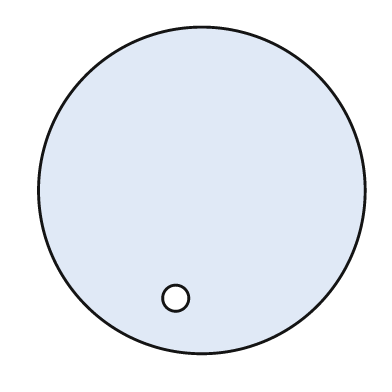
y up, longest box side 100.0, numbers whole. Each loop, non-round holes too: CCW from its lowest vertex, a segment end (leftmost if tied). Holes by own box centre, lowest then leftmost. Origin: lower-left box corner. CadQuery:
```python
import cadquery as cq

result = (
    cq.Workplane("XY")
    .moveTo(50.0, 50.0)
    .circle(50.0)
    .moveTo(42.0, 17.0)
    .circle(4.0)
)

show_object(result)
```